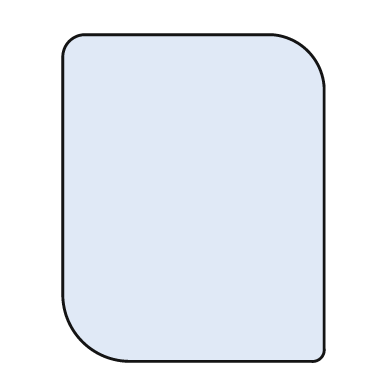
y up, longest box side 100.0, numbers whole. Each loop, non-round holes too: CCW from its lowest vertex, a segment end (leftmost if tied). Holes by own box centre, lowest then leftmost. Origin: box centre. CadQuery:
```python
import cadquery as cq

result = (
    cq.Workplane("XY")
    .moveTo(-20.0, -50.0)
    .lineTo(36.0, -50.0)
    .threePointArc((39.0, -49.0), (40.0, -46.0))
    .lineTo(40.0, 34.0)
    .threePointArc((35.0, 45.0), (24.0, 50.0))
    .lineTo(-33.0, 50.0)
    .threePointArc((-38.0, 48.0), (-40.0, 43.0))
    .lineTo(-40.0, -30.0)
    .threePointArc((-34.0, -44.0), (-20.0, -50.0))
    .close()
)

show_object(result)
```